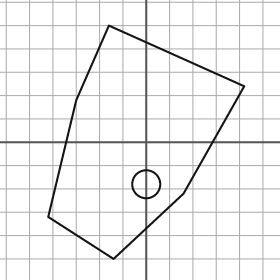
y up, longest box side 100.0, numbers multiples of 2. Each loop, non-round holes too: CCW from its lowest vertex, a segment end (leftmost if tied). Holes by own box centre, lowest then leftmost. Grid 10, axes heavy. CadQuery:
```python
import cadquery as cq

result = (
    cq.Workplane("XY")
    .moveTo(-14.0, -50.0)
    .lineTo(16.0, -22.0)
    .lineTo(42.0, 24.0)
    .lineTo(-16.0, 50.0)
    .lineTo(-30.0, 18.0)
    .lineTo(-42.0, -32.0)
    .close()
    .moveTo(0.0, -18.0)
    .circle(6.0)
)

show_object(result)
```